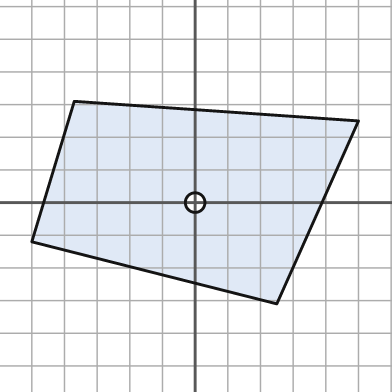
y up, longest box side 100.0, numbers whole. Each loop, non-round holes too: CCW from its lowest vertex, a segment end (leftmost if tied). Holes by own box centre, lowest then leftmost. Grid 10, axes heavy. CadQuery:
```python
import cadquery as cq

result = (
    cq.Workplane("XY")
    .moveTo(25.0, -31.0)
    .lineTo(50.0, 25.0)
    .lineTo(-37.0, 31.0)
    .lineTo(-50.0, -12.0)
    .close()
    .moveTo(0.0, 0.0)
    .circle(3.0)
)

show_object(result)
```